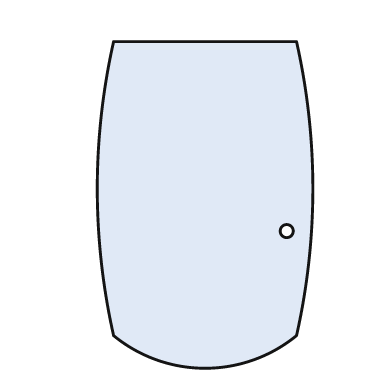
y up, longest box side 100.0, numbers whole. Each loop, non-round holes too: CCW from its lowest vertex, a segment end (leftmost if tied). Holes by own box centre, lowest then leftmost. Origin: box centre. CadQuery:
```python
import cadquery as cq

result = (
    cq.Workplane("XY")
    .moveTo(-28.0, -40.0)
    .threePointArc((0.0, -50.0), (28.0, -40.0))
    .threePointArc((33.0, 5.0), (28.0, 50.0))
    .lineTo(-28.0, 50.0)
    .threePointArc((-33.0, 5.0), (-28.0, -40.0))
    .close()
    .moveTo(25.0, -8.0)
    .circle(2.0)
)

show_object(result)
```